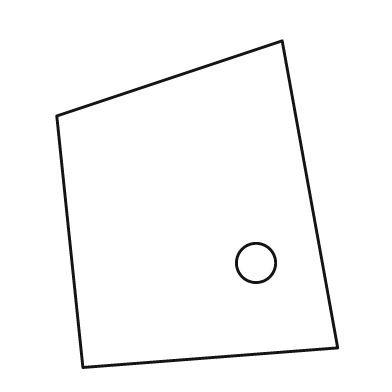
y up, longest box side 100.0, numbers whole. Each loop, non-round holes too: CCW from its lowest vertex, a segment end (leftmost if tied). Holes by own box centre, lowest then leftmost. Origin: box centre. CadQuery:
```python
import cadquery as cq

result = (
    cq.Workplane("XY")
    .moveTo(-35.0, -50.0)
    .lineTo(43.0, -44.0)
    .lineTo(26.0, 50.0)
    .lineTo(-43.0, 27.0)
    .close()
    .moveTo(18.0, -18.0)
    .circle(6.0)
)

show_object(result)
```